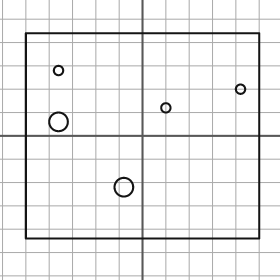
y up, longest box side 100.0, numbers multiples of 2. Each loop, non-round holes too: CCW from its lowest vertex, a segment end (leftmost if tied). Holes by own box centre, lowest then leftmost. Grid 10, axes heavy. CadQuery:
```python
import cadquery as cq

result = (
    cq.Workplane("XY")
    .moveTo(-50.0, -44.0)
    .lineTo(50.0, -44.0)
    .lineTo(50.0, 44.0)
    .lineTo(-50.0, 44.0)
    .close()
    .moveTo(-8.0, -22.0)
    .circle(4.0)
    .moveTo(-36.0, 6.0)
    .circle(4.0)
    .moveTo(10.0, 12.0)
    .circle(2.0)
    .moveTo(42.0, 20.0)
    .circle(2.0)
    .moveTo(-36.0, 28.0)
    .circle(2.0)
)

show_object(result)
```